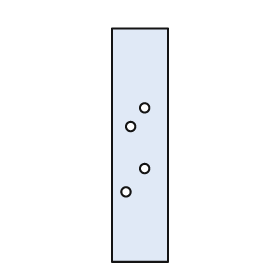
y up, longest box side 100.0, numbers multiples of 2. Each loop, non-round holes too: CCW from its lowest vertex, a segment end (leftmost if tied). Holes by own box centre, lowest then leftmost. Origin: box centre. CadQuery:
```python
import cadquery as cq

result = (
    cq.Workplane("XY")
    .moveTo(-12.0, -50.0)
    .lineTo(12.0, -50.0)
    .lineTo(12.0, 50.0)
    .lineTo(-12.0, 50.0)
    .close()
    .moveTo(-6.0, -20.0)
    .circle(2.0)
    .moveTo(2.0, -10.0)
    .circle(2.0)
    .moveTo(-4.0, 8.0)
    .circle(2.0)
    .moveTo(2.0, 16.0)
    .circle(2.0)
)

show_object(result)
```